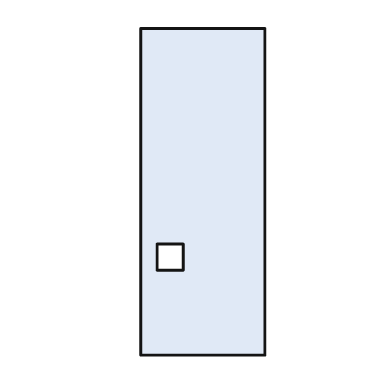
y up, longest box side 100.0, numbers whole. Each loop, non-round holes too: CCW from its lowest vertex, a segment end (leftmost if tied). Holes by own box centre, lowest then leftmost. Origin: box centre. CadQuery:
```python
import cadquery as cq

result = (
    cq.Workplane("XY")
    .moveTo(-19.0, -50.0)
    .lineTo(19.0, -50.0)
    .lineTo(19.0, 50.0)
    .lineTo(-19.0, 50.0)
    .close()
    .moveTo(-14.0, -24.0)
    .lineTo(-6.0, -24.0)
    .lineTo(-6.0, -16.0)
    .lineTo(-14.0, -16.0)
    .close()
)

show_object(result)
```